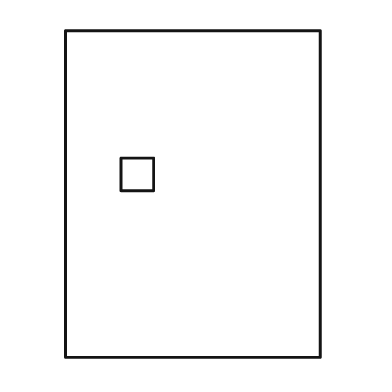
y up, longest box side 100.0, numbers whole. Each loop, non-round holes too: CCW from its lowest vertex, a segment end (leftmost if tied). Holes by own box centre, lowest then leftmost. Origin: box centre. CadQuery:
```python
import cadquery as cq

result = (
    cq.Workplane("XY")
    .moveTo(-39.0, -50.0)
    .lineTo(39.0, -50.0)
    .lineTo(39.0, 50.0)
    .lineTo(-39.0, 50.0)
    .close()
    .moveTo(-22.0, 1.0)
    .lineTo(-12.0, 1.0)
    .lineTo(-12.0, 11.0)
    .lineTo(-22.0, 11.0)
    .close()
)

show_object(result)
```